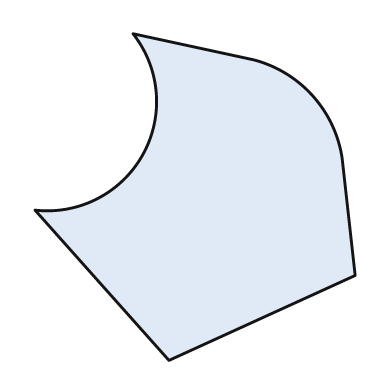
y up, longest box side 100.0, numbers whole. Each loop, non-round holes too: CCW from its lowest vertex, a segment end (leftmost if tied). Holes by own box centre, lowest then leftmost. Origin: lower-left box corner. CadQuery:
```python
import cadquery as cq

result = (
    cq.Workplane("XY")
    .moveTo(41.0, 0.0)
    .lineTo(98.0, 26.0)
    .lineTo(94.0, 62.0)
    .threePointArc((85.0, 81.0), (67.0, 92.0))
    .lineTo(30.0, 100.0)
    .threePointArc((33.0, 63.0), (0.0, 46.0))
    .close()
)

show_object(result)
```